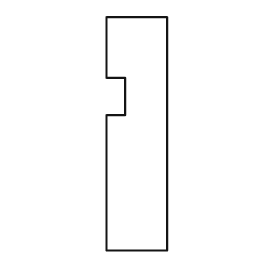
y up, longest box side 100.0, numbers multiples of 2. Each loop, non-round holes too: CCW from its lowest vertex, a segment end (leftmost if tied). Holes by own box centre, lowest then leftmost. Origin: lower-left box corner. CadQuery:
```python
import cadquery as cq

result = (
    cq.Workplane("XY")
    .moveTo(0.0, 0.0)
    .lineTo(26.0, 0.0)
    .lineTo(26.0, 100.0)
    .lineTo(0.0, 100.0)
    .lineTo(0.0, 74.0)
    .lineTo(8.0, 74.0)
    .lineTo(8.0, 58.0)
    .lineTo(0.0, 58.0)
    .close()
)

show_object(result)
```